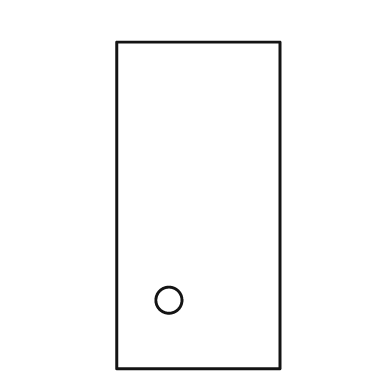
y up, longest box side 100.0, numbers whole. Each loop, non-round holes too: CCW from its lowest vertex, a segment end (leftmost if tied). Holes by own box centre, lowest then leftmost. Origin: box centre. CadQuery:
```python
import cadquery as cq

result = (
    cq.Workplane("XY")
    .moveTo(-25.0, -50.0)
    .lineTo(25.0, -50.0)
    .lineTo(25.0, 50.0)
    .lineTo(-25.0, 50.0)
    .close()
    .moveTo(-9.0, -29.0)
    .circle(4.0)
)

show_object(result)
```